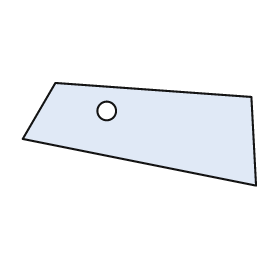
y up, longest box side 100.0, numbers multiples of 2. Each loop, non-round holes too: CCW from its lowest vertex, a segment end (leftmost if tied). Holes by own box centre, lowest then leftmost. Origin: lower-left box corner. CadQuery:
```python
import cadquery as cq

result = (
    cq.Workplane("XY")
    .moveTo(100.0, 0.0)
    .lineTo(98.0, 38.0)
    .lineTo(14.0, 44.0)
    .lineTo(0.0, 20.0)
    .close()
    .moveTo(36.0, 32.0)
    .circle(4.0)
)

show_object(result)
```